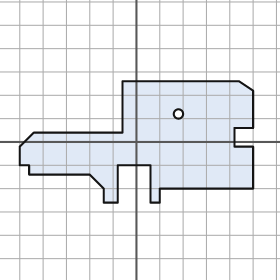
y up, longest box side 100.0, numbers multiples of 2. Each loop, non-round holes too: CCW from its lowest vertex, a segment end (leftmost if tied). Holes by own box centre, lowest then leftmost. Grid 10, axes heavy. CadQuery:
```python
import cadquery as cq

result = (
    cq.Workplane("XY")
    .moveTo(-14.0, -26.0)
    .lineTo(-8.0, -26.0)
    .lineTo(-8.0, -10.0)
    .lineTo(6.0, -10.0)
    .lineTo(6.0, -26.0)
    .lineTo(10.0, -26.0)
    .lineTo(10.0, -20.0)
    .lineTo(50.0, -20.0)
    .lineTo(50.0, -2.0)
    .lineTo(42.0, -2.0)
    .lineTo(42.0, 6.0)
    .lineTo(50.0, 6.0)
    .lineTo(50.0, 22.0)
    .lineTo(44.0, 26.0)
    .lineTo(-6.0, 26.0)
    .lineTo(-6.0, 4.0)
    .lineTo(-44.0, 4.0)
    .lineTo(-50.0, -2.0)
    .lineTo(-50.0, -10.0)
    .lineTo(-46.0, -10.0)
    .lineTo(-46.0, -14.0)
    .lineTo(-20.0, -14.0)
    .lineTo(-14.0, -20.0)
    .close()
    .moveTo(18.0, 12.0)
    .circle(2.0)
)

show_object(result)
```